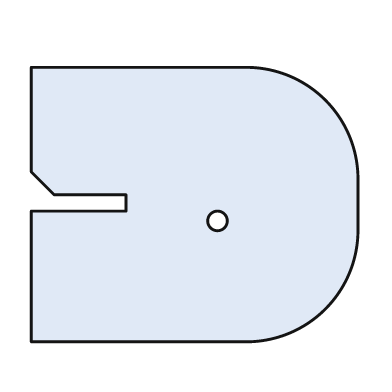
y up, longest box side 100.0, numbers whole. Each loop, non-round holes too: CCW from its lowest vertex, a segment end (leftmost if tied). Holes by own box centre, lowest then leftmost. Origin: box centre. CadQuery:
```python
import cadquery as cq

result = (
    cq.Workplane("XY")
    .moveTo(-50.0, -42.0)
    .lineTo(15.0, -42.0)
    .threePointArc((40.0, -32.0), (50.0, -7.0))
    .lineTo(50.0, 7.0)
    .threePointArc((40.0, 32.0), (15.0, 42.0))
    .lineTo(-50.0, 42.0)
    .lineTo(-50.0, 10.0)
    .lineTo(-43.0, 3.0)
    .lineTo(-21.0, 3.0)
    .lineTo(-21.0, -2.0)
    .lineTo(-50.0, -2.0)
    .close()
    .moveTo(7.0, -5.0)
    .circle(3.0)
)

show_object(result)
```